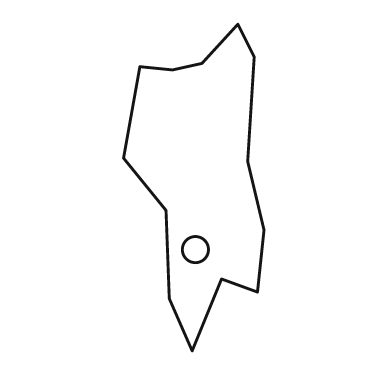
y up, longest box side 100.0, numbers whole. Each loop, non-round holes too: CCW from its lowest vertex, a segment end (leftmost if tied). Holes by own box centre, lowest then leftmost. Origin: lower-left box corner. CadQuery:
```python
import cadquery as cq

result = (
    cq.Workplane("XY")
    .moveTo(21.0, 0.0)
    .lineTo(30.0, 22.0)
    .lineTo(41.0, 18.0)
    .lineTo(43.0, 37.0)
    .lineTo(38.0, 58.0)
    .lineTo(40.0, 90.0)
    .lineTo(35.0, 100.0)
    .lineTo(24.0, 88.0)
    .lineTo(15.0, 86.0)
    .lineTo(5.0, 87.0)
    .lineTo(0.0, 59.0)
    .lineTo(13.0, 43.0)
    .lineTo(14.0, 16.0)
    .close()
    .moveTo(22.0, 31.0)
    .circle(4.0)
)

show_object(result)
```